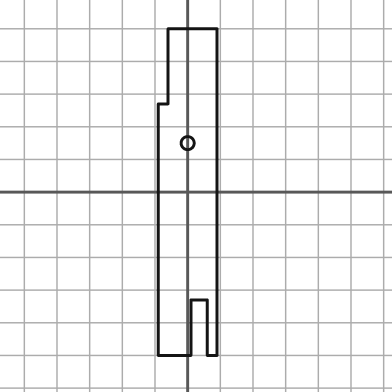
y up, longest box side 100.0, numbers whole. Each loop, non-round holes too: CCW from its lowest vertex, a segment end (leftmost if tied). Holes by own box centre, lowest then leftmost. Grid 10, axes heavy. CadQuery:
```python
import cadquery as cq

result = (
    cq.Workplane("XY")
    .moveTo(-9.0, -50.0)
    .lineTo(1.0, -50.0)
    .lineTo(1.0, -33.0)
    .lineTo(6.0, -33.0)
    .lineTo(6.0, -50.0)
    .lineTo(9.0, -50.0)
    .lineTo(9.0, 50.0)
    .lineTo(-6.0, 50.0)
    .lineTo(-6.0, 27.0)
    .lineTo(-9.0, 27.0)
    .close()
    .moveTo(0.0, 15.0)
    .circle(2.0)
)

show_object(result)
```